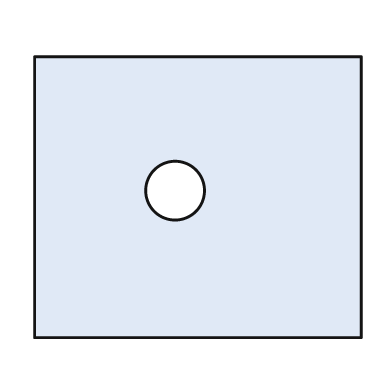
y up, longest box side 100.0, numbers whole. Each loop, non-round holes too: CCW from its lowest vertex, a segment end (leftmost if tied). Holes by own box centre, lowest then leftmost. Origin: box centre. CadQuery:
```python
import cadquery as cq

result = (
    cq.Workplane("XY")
    .moveTo(-50.0, -43.0)
    .lineTo(50.0, -43.0)
    .lineTo(50.0, 43.0)
    .lineTo(-50.0, 43.0)
    .close()
    .moveTo(-7.0, 2.0)
    .circle(9.0)
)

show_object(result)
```